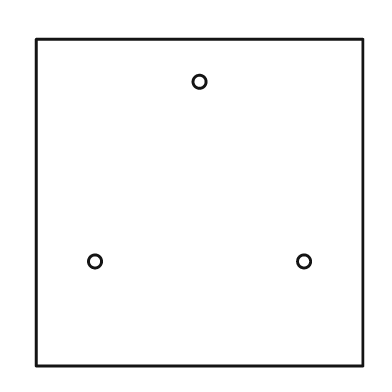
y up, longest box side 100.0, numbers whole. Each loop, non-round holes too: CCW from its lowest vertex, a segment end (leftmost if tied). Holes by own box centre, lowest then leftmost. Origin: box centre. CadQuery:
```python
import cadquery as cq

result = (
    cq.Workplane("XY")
    .moveTo(-50.0, -50.0)
    .lineTo(50.0, -50.0)
    .lineTo(50.0, 50.0)
    .lineTo(-50.0, 50.0)
    .close()
    .moveTo(-32.0, -18.0)
    .circle(2.0)
    .moveTo(32.0, -18.0)
    .circle(2.0)
    .moveTo(0.0, 37.0)
    .circle(2.0)
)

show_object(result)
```